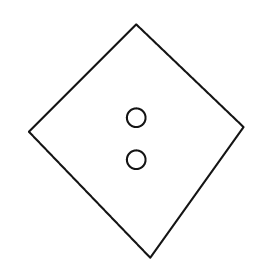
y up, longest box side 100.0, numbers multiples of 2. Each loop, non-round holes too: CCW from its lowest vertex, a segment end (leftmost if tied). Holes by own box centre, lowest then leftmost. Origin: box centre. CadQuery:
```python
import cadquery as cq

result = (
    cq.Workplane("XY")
    .moveTo(6.0, -50.0)
    .lineTo(46.0, 6.0)
    .lineTo(0.0, 50.0)
    .lineTo(-46.0, 4.0)
    .close()
    .moveTo(0.0, -8.0)
    .circle(4.0)
    .moveTo(0.0, 10.0)
    .circle(4.0)
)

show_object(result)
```